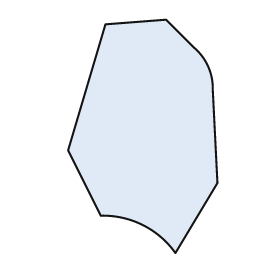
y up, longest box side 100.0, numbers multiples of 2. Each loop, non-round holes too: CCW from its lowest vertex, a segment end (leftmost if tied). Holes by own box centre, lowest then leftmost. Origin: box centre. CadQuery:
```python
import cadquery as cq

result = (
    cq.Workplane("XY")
    .moveTo(14.0, -50.0)
    .lineTo(32.0, -20.0)
    .lineTo(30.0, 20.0)
    .threePointArc((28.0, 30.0), (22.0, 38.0))
    .lineTo(10.0, 50.0)
    .lineTo(-16.0, 48.0)
    .lineTo(-32.0, -6.0)
    .lineTo(-18.0, -34.0)
    .threePointArc((0.0, -38.0), (14.0, -50.0))
    .close()
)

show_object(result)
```